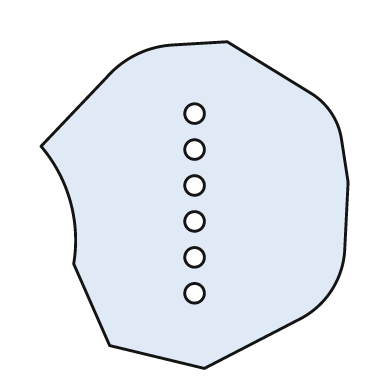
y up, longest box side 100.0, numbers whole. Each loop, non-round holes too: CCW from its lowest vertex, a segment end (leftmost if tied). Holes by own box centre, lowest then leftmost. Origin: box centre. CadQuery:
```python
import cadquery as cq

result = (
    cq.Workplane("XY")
    .moveTo(3.0, -50.0)
    .lineTo(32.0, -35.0)
    .threePointArc((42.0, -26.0), (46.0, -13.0))
    .lineTo(47.0, 7.0)
    .lineTo(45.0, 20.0)
    .threePointArc((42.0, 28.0), (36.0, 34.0))
    .lineTo(10.0, 50.0)
    .lineTo(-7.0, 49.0)
    .threePointArc((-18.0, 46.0), (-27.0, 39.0))
    .lineTo(-47.0, 18.0)
    .threePointArc((-38.0, 1.0), (-37.0, -18.0))
    .lineTo(-26.0, -43.0)
    .close()
    .moveTo(0.0, -27.0)
    .circle(3.0)
    .moveTo(0.0, -16.0)
    .circle(3.0)
    .moveTo(0.0, -5.0)
    .circle(3.0)
    .moveTo(0.0, 6.0)
    .circle(3.0)
    .moveTo(0.0, 17.0)
    .circle(3.0)
    .moveTo(0.0, 28.0)
    .circle(3.0)
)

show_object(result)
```